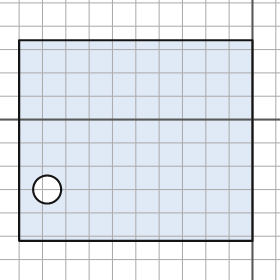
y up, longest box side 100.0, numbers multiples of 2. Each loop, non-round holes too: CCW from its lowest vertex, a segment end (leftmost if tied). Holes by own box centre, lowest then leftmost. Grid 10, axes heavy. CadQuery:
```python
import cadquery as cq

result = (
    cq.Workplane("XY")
    .moveTo(-100.0, -52.0)
    .lineTo(0.0, -52.0)
    .lineTo(0.0, 34.0)
    .lineTo(-100.0, 34.0)
    .close()
    .moveTo(-88.0, -30.0)
    .circle(6.0)
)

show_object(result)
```